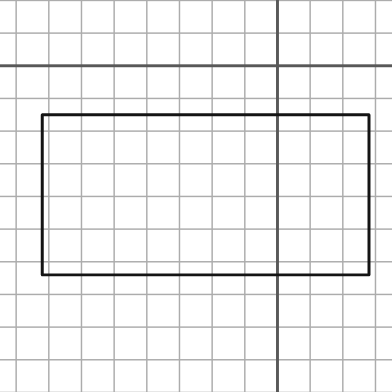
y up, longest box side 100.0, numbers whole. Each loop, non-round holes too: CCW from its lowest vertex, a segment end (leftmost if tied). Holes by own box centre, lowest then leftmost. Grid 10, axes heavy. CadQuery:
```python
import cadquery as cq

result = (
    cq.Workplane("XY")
    .moveTo(-72.0, -64.0)
    .lineTo(28.0, -64.0)
    .lineTo(28.0, -15.0)
    .lineTo(-72.0, -15.0)
    .close()
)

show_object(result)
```